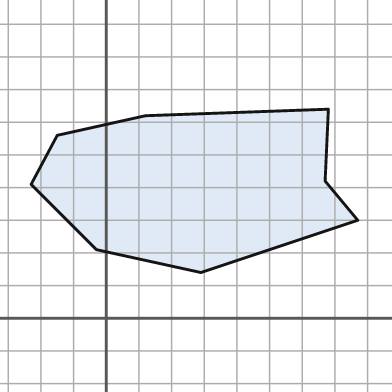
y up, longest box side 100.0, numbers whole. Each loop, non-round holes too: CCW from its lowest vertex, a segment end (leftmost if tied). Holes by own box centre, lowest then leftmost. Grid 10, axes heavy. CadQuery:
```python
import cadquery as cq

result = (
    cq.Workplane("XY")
    .moveTo(29.0, 14.0)
    .lineTo(77.0, 30.0)
    .lineTo(67.0, 42.0)
    .lineTo(68.0, 64.0)
    .lineTo(12.0, 62.0)
    .lineTo(-15.0, 56.0)
    .lineTo(-23.0, 41.0)
    .lineTo(-3.0, 21.0)
    .close()
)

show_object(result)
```